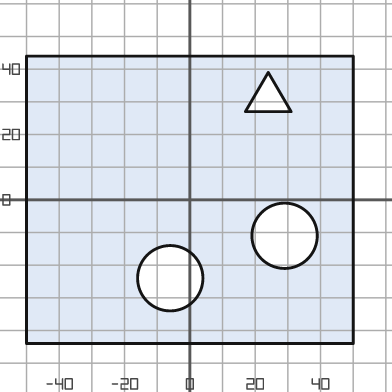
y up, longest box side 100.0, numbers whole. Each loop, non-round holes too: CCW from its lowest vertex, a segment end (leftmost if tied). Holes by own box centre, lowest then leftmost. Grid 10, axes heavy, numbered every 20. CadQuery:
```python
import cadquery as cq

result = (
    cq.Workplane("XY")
    .moveTo(-50.0, -44.0)
    .lineTo(50.0, -44.0)
    .lineTo(50.0, 44.0)
    .lineTo(-50.0, 44.0)
    .close()
    .moveTo(-6.0, -24.0)
    .circle(10.0)
    .moveTo(29.0, -11.0)
    .circle(10.0)
    .moveTo(17.0, 27.0)
    .lineTo(31.0, 27.0)
    .lineTo(24.0, 39.0)
    .close()
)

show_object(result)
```